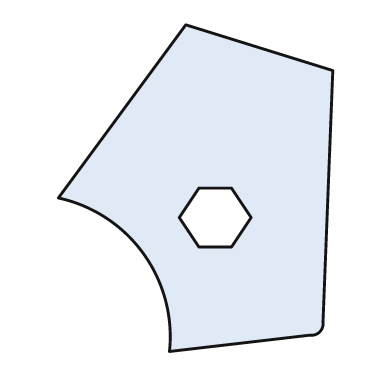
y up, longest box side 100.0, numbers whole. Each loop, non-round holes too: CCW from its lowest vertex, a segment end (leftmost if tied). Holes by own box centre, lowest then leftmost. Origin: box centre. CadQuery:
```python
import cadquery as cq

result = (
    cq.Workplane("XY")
    .moveTo(-8.0, -50.0)
    .lineTo(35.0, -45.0)
    .threePointArc((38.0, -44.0), (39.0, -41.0))
    .lineTo(42.0, 36.0)
    .lineTo(-3.0, 50.0)
    .lineTo(-42.0, -3.0)
    .threePointArc((-16.0, -20.0), (-8.0, -50.0))
    .close()
    .moveTo(1.0, -18.0)
    .lineTo(11.0, -18.0)
    .lineTo(17.0, -9.0)
    .lineTo(11.0, 0.0)
    .lineTo(1.0, 0.0)
    .lineTo(-5.0, -9.0)
    .close()
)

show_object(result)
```